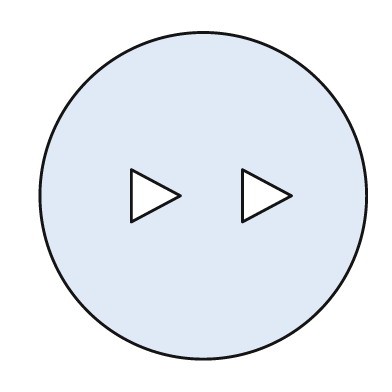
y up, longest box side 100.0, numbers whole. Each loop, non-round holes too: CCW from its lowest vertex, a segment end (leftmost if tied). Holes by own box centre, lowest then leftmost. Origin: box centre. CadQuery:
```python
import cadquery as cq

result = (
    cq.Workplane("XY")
    .moveTo(0.0, 0.0)
    .circle(50.0)
    .moveTo(-22.0, -8.0)
    .lineTo(-7.0, 0.0)
    .lineTo(-22.0, 8.0)
    .close()
    .moveTo(12.0, -8.0)
    .lineTo(27.0, 0.0)
    .lineTo(12.0, 8.0)
    .close()
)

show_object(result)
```